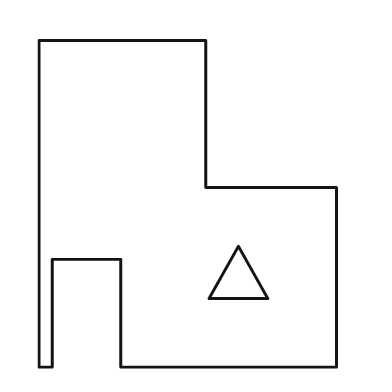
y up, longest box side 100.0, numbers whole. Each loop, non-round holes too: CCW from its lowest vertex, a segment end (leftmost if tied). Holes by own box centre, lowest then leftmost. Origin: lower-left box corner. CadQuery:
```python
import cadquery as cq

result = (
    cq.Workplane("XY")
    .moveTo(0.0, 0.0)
    .lineTo(4.0, 0.0)
    .lineTo(4.0, 33.0)
    .lineTo(25.0, 33.0)
    .lineTo(25.0, 0.0)
    .lineTo(91.0, 0.0)
    .lineTo(91.0, 55.0)
    .lineTo(51.0, 55.0)
    .lineTo(51.0, 100.0)
    .lineTo(0.0, 100.0)
    .close()
    .moveTo(52.0, 21.0)
    .lineTo(70.0, 21.0)
    .lineTo(61.0, 37.0)
    .close()
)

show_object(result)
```